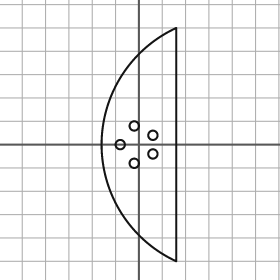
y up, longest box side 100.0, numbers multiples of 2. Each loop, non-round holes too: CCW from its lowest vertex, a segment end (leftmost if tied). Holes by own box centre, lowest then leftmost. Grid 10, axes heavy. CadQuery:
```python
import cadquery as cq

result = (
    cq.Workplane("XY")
    .moveTo(16.0, -50.0)
    .lineTo(16.0, 50.0)
    .threePointArc((-16.0, 0.0), (16.0, -50.0))
    .close()
    .moveTo(-2.0, -8.0)
    .circle(2.0)
    .moveTo(6.0, -4.0)
    .circle(2.0)
    .moveTo(-8.0, 0.0)
    .circle(2.0)
    .moveTo(6.0, 4.0)
    .circle(2.0)
    .moveTo(-2.0, 8.0)
    .circle(2.0)
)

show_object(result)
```